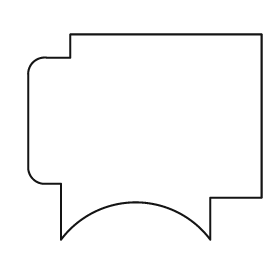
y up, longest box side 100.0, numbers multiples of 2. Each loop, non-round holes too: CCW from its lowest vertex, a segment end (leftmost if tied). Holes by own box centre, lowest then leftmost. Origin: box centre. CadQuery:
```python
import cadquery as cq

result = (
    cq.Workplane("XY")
    .moveTo(-36.0, -44.0)
    .threePointArc((-4.0, -28.0), (28.0, -44.0))
    .lineTo(28.0, -26.0)
    .lineTo(50.0, -26.0)
    .lineTo(50.0, 44.0)
    .lineTo(-32.0, 44.0)
    .lineTo(-32.0, 34.0)
    .lineTo(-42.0, 34.0)
    .threePointArc((-48.0, 32.0), (-50.0, 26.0))
    .lineTo(-50.0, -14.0)
    .threePointArc((-48.0, -18.0), (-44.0, -20.0))
    .lineTo(-36.0, -20.0)
    .close()
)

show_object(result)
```